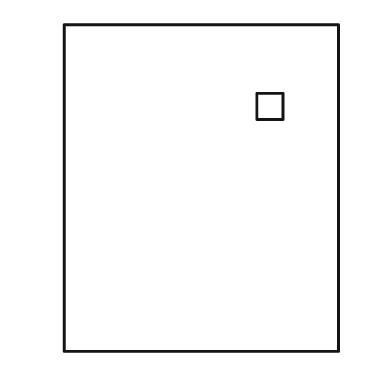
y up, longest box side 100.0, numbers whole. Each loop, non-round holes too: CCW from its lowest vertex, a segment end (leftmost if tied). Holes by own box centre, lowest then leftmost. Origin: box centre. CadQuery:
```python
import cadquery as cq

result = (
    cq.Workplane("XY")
    .moveTo(-42.0, -50.0)
    .lineTo(42.0, -50.0)
    .lineTo(42.0, 50.0)
    .lineTo(-42.0, 50.0)
    .close()
    .moveTo(17.0, 21.0)
    .lineTo(25.0, 21.0)
    .lineTo(25.0, 29.0)
    .lineTo(17.0, 29.0)
    .close()
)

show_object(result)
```